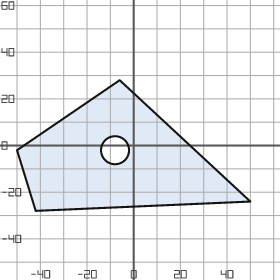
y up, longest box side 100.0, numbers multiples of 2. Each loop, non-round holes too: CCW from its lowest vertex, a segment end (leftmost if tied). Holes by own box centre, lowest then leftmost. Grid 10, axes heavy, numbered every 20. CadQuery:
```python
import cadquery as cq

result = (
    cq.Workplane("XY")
    .moveTo(-42.0, -28.0)
    .lineTo(50.0, -24.0)
    .lineTo(-6.0, 28.0)
    .lineTo(-50.0, -2.0)
    .close()
    .moveTo(-8.0, -2.0)
    .circle(6.0)
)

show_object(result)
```